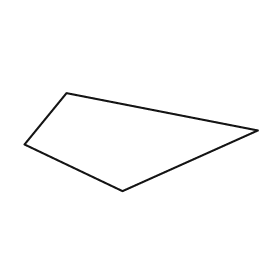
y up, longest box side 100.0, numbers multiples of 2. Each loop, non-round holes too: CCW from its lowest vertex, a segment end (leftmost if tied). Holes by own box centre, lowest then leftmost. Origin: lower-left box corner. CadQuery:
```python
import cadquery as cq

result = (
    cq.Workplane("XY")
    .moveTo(42.0, 0.0)
    .lineTo(100.0, 26.0)
    .lineTo(18.0, 42.0)
    .lineTo(0.0, 20.0)
    .close()
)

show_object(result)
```